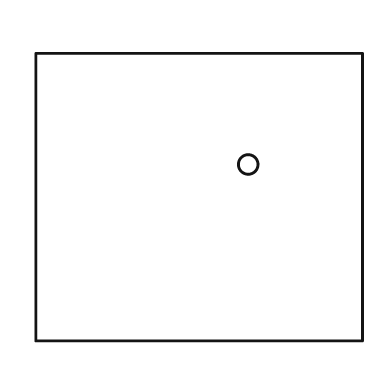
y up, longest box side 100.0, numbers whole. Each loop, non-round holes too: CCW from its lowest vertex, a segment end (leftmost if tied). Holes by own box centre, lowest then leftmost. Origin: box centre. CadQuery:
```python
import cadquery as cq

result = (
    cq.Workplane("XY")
    .moveTo(-50.0, -44.0)
    .lineTo(50.0, -44.0)
    .lineTo(50.0, 44.0)
    .lineTo(-50.0, 44.0)
    .close()
    .moveTo(15.0, 10.0)
    .circle(3.0)
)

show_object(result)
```